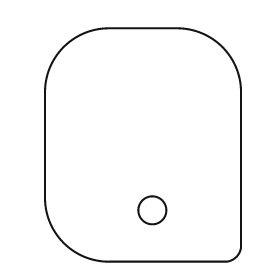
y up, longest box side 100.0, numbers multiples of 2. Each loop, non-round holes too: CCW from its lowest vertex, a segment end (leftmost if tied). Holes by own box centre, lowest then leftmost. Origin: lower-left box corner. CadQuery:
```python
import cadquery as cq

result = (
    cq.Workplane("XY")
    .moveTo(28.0, 0.0)
    .lineTo(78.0, 0.0)
    .threePointArc((82.0, 2.0), (84.0, 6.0))
    .lineTo(84.0, 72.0)
    .threePointArc((76.0, 92.0), (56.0, 100.0))
    .lineTo(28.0, 100.0)
    .threePointArc((8.0, 92.0), (0.0, 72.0))
    .lineTo(0.0, 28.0)
    .threePointArc((8.0, 8.0), (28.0, 0.0))
    .close()
    .moveTo(46.0, 22.0)
    .circle(6.0)
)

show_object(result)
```